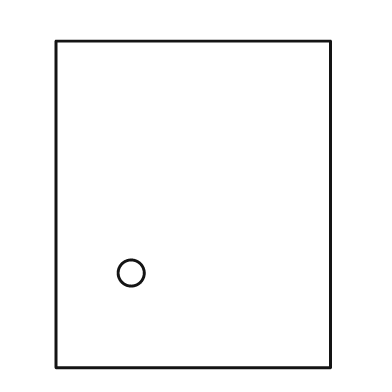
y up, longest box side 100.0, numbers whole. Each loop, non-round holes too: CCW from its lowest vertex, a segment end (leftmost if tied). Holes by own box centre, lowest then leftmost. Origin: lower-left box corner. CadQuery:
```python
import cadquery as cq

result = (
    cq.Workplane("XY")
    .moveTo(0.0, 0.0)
    .lineTo(84.0, 0.0)
    .lineTo(84.0, 100.0)
    .lineTo(0.0, 100.0)
    .close()
    .moveTo(23.0, 29.0)
    .circle(4.0)
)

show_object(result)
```